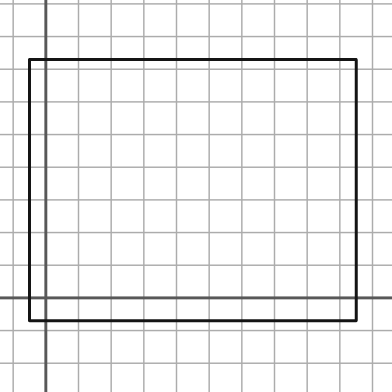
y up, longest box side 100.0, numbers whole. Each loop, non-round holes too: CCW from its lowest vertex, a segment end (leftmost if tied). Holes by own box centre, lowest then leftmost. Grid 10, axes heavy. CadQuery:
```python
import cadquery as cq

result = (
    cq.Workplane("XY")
    .moveTo(-5.0, -7.0)
    .lineTo(95.0, -7.0)
    .lineTo(95.0, 73.0)
    .lineTo(-5.0, 73.0)
    .close()
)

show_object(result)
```